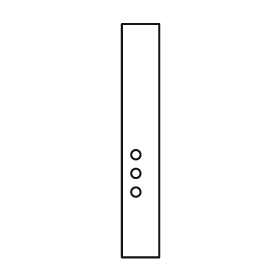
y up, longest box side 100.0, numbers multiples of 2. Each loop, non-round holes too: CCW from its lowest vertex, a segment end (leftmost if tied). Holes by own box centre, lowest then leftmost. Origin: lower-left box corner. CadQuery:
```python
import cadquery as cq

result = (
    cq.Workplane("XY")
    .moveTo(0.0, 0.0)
    .lineTo(16.0, 0.0)
    .lineTo(16.0, 100.0)
    .lineTo(0.0, 100.0)
    .close()
    .moveTo(6.0, 28.0)
    .circle(2.0)
    .moveTo(6.0, 36.0)
    .circle(2.0)
    .moveTo(6.0, 44.0)
    .circle(2.0)
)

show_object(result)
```